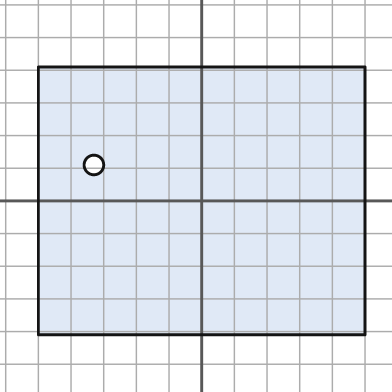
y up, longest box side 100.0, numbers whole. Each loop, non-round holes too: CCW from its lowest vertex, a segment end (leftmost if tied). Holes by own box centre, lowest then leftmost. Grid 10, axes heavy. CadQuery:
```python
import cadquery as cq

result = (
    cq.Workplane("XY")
    .moveTo(-50.0, -41.0)
    .lineTo(50.0, -41.0)
    .lineTo(50.0, 41.0)
    .lineTo(-50.0, 41.0)
    .close()
    .moveTo(-33.0, 11.0)
    .circle(3.0)
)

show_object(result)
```